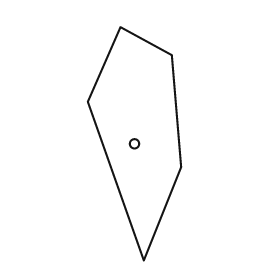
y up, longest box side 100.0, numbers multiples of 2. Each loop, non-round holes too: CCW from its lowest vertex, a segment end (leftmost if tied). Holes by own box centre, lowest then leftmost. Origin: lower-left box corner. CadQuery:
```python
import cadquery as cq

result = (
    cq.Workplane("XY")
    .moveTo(24.0, 0.0)
    .lineTo(40.0, 40.0)
    .lineTo(36.0, 88.0)
    .lineTo(14.0, 100.0)
    .lineTo(0.0, 68.0)
    .close()
    .moveTo(20.0, 50.0)
    .circle(2.0)
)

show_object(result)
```